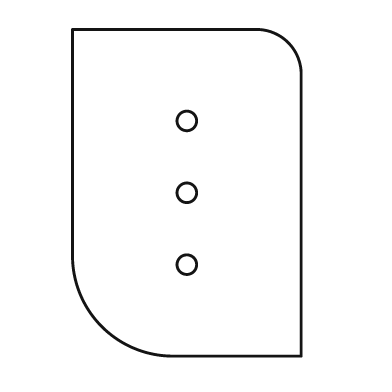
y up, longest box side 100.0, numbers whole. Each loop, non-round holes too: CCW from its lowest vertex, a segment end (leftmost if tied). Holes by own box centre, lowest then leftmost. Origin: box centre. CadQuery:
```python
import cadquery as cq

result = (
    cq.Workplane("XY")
    .moveTo(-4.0, -50.0)
    .lineTo(35.0, -50.0)
    .lineTo(35.0, 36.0)
    .threePointArc((31.0, 46.0), (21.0, 50.0))
    .lineTo(-35.0, 50.0)
    .lineTo(-35.0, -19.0)
    .threePointArc((-26.0, -41.0), (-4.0, -50.0))
    .close()
    .moveTo(0.0, -22.0)
    .circle(3.0)
    .moveTo(0.0, 0.0)
    .circle(3.0)
    .moveTo(0.0, 22.0)
    .circle(3.0)
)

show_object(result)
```